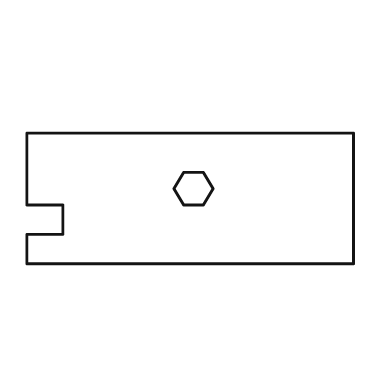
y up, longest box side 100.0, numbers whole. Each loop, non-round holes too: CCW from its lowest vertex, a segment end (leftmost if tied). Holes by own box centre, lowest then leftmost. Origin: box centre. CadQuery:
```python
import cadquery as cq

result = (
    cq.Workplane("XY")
    .moveTo(-50.0, -20.0)
    .lineTo(50.0, -20.0)
    .lineTo(50.0, 20.0)
    .lineTo(-50.0, 20.0)
    .lineTo(-50.0, -2.0)
    .lineTo(-39.0, -2.0)
    .lineTo(-39.0, -11.0)
    .lineTo(-50.0, -11.0)
    .close()
    .moveTo(-2.0, -2.0)
    .lineTo(4.0, -2.0)
    .lineTo(7.0, 3.0)
    .lineTo(4.0, 8.0)
    .lineTo(-2.0, 8.0)
    .lineTo(-5.0, 3.0)
    .close()
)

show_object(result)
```